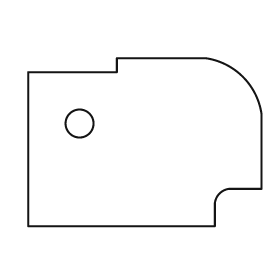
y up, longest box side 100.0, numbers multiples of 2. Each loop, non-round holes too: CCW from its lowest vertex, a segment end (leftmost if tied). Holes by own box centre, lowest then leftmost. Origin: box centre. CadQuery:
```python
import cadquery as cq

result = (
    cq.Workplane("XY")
    .moveTo(-50.0, -36.0)
    .lineTo(30.0, -36.0)
    .lineTo(30.0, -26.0)
    .threePointArc((32.0, -22.0), (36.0, -20.0))
    .lineTo(50.0, -20.0)
    .lineTo(50.0, 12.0)
    .threePointArc((42.0, 28.0), (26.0, 36.0))
    .lineTo(-12.0, 36.0)
    .lineTo(-12.0, 30.0)
    .lineTo(-50.0, 30.0)
    .close()
    .moveTo(-28.0, 8.0)
    .circle(6.0)
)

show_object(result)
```